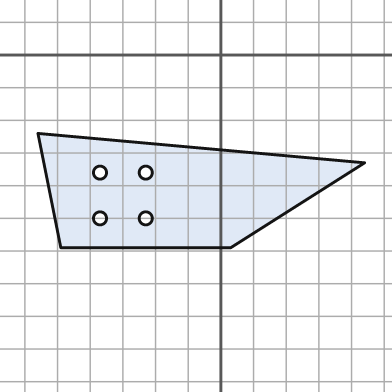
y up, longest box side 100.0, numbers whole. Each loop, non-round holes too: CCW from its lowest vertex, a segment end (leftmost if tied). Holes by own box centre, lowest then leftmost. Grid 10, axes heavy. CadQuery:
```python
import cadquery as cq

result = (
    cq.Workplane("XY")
    .moveTo(-49.0, -59.0)
    .lineTo(3.0, -59.0)
    .lineTo(44.0, -33.0)
    .lineTo(-56.0, -24.0)
    .close()
    .moveTo(-37.0, -50.0)
    .circle(2.0)
    .moveTo(-23.0, -50.0)
    .circle(2.0)
    .moveTo(-37.0, -36.0)
    .circle(2.0)
    .moveTo(-23.0, -36.0)
    .circle(2.0)
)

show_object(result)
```